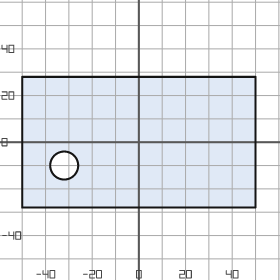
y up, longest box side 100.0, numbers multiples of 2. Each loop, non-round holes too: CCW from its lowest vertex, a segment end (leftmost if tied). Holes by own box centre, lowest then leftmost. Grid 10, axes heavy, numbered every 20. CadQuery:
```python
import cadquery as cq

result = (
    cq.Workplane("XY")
    .moveTo(-50.0, -28.0)
    .lineTo(50.0, -28.0)
    .lineTo(50.0, 28.0)
    .lineTo(-50.0, 28.0)
    .close()
    .moveTo(-32.0, -10.0)
    .circle(6.0)
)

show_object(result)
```